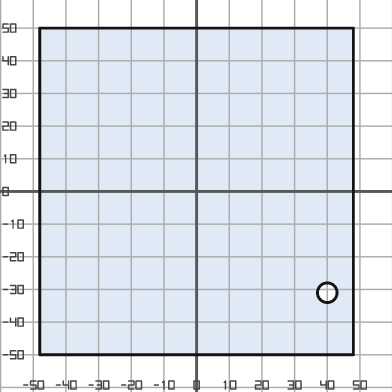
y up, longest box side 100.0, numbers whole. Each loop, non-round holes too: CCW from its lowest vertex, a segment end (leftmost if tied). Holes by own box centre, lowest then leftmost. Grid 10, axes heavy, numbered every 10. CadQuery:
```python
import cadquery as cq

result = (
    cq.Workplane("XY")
    .moveTo(-48.0, -50.0)
    .lineTo(48.0, -50.0)
    .lineTo(48.0, 50.0)
    .lineTo(-48.0, 50.0)
    .close()
    .moveTo(40.0, -31.0)
    .circle(3.0)
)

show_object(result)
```